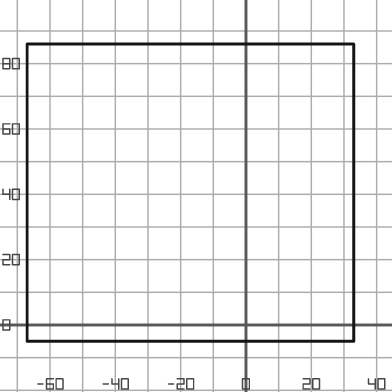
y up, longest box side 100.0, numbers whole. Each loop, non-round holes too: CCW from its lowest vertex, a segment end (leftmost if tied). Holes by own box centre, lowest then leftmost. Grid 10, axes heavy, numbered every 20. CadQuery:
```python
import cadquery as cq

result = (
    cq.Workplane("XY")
    .moveTo(-67.0, -5.0)
    .lineTo(33.0, -5.0)
    .lineTo(33.0, 86.0)
    .lineTo(-67.0, 86.0)
    .close()
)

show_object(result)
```